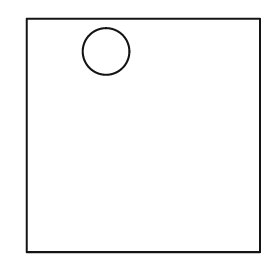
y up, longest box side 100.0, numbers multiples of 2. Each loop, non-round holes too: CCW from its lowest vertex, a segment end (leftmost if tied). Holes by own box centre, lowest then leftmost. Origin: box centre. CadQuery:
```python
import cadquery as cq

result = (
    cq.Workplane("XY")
    .moveTo(-50.0, -50.0)
    .lineTo(50.0, -50.0)
    .lineTo(50.0, 50.0)
    .lineTo(-50.0, 50.0)
    .close()
    .moveTo(-16.0, 36.0)
    .circle(10.0)
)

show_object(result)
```